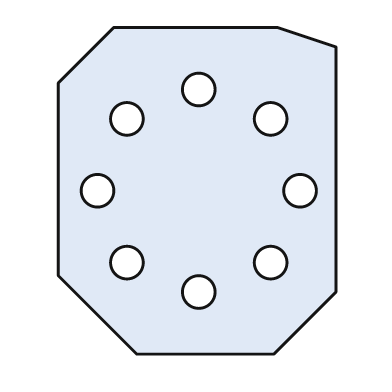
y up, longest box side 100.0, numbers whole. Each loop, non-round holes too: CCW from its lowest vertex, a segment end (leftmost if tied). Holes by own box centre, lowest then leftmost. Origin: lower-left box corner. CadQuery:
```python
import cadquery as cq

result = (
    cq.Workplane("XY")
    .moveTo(24.0, 0.0)
    .lineTo(66.0, 0.0)
    .lineTo(85.0, 19.0)
    .lineTo(85.0, 94.0)
    .lineTo(67.0, 100.0)
    .lineTo(17.0, 100.0)
    .lineTo(0.0, 83.0)
    .lineTo(0.0, 24.0)
    .close()
    .moveTo(43.0, 19.0)
    .circle(5.0)
    .moveTo(21.0, 28.0)
    .circle(5.0)
    .moveTo(65.0, 28.0)
    .circle(5.0)
    .moveTo(12.0, 50.0)
    .circle(5.0)
    .moveTo(74.0, 50.0)
    .circle(5.0)
    .moveTo(21.0, 72.0)
    .circle(5.0)
    .moveTo(65.0, 72.0)
    .circle(5.0)
    .moveTo(43.0, 81.0)
    .circle(5.0)
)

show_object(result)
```